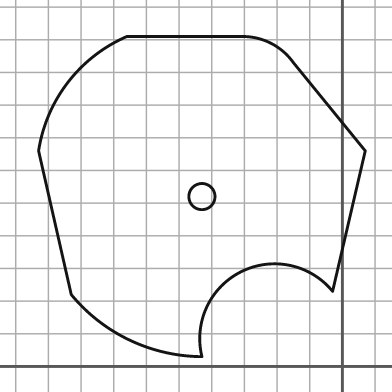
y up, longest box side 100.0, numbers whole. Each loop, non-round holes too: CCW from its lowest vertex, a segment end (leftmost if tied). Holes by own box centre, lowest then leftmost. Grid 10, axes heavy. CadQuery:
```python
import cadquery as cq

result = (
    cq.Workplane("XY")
    .moveTo(-43.0, 3.0)
    .threePointArc((-31.0, 29.0), (-3.0, 23.0))
    .lineTo(7.0, 66.0)
    .lineTo(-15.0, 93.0)
    .threePointArc((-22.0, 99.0), (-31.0, 101.0))
    .lineTo(-66.0, 101.0)
    .threePointArc((-84.0, 87.0), (-93.0, 66.0))
    .lineTo(-83.0, 22.0)
    .threePointArc((-65.0, 8.0), (-43.0, 3.0))
    .close()
    .moveTo(-43.0, 52.0)
    .circle(4.0)
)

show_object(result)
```